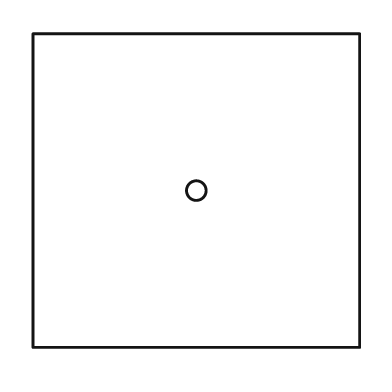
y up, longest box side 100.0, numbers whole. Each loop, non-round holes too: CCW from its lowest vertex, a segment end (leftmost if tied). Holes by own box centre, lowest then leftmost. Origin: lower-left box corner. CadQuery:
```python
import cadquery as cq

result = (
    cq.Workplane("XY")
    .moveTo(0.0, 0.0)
    .lineTo(100.0, 0.0)
    .lineTo(100.0, 96.0)
    .lineTo(0.0, 96.0)
    .close()
    .moveTo(50.0, 48.0)
    .circle(3.0)
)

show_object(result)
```